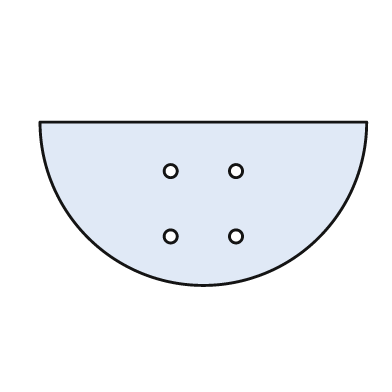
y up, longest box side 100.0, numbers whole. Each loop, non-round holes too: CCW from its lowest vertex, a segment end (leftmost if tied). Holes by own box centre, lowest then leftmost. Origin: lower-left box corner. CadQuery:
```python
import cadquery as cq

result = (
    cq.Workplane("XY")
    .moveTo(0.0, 50.0)
    .threePointArc((50.0, 0.0), (100.0, 50.0))
    .close()
    .moveTo(40.0, 15.0)
    .circle(2.0)
    .moveTo(60.0, 15.0)
    .circle(2.0)
    .moveTo(40.0, 35.0)
    .circle(2.0)
    .moveTo(60.0, 35.0)
    .circle(2.0)
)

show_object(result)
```